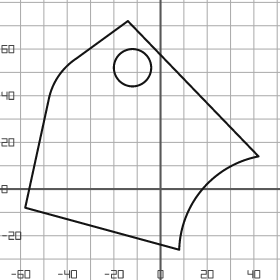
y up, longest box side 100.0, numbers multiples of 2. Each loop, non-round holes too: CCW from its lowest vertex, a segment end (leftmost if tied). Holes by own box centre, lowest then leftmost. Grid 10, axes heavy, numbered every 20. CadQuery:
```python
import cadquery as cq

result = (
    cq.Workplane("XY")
    .moveTo(8.0, -26.0)
    .threePointArc((18.0, 0.0), (42.0, 14.0))
    .lineTo(-14.0, 72.0)
    .lineTo(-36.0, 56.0)
    .threePointArc((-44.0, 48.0), (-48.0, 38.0))
    .lineTo(-58.0, -8.0)
    .close()
    .moveTo(-12.0, 52.0)
    .circle(8.0)
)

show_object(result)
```